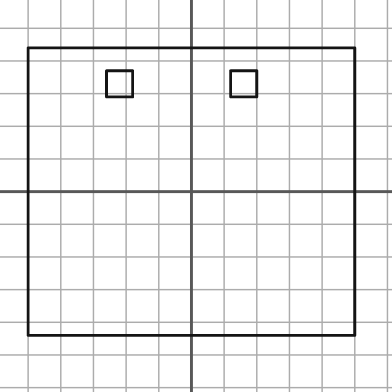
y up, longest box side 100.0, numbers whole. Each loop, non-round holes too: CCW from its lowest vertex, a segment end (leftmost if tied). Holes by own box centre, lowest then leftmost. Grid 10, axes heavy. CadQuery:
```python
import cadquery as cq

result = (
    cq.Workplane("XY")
    .moveTo(-50.0, -44.0)
    .lineTo(50.0, -44.0)
    .lineTo(50.0, 44.0)
    .lineTo(-50.0, 44.0)
    .close()
    .moveTo(-26.0, 29.0)
    .lineTo(-18.0, 29.0)
    .lineTo(-18.0, 37.0)
    .lineTo(-26.0, 37.0)
    .close()
    .moveTo(12.0, 29.0)
    .lineTo(20.0, 29.0)
    .lineTo(20.0, 37.0)
    .lineTo(12.0, 37.0)
    .close()
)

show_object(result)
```